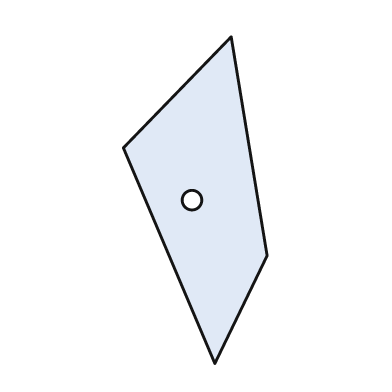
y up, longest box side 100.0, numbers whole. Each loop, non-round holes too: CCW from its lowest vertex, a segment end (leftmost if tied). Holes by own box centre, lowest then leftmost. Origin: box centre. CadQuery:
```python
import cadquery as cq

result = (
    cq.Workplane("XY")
    .moveTo(6.0, -50.0)
    .lineTo(22.0, -17.0)
    .lineTo(11.0, 50.0)
    .lineTo(-22.0, 16.0)
    .close()
    .moveTo(-1.0, 0.0)
    .circle(3.0)
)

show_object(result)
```